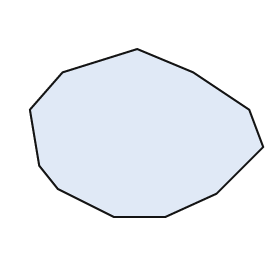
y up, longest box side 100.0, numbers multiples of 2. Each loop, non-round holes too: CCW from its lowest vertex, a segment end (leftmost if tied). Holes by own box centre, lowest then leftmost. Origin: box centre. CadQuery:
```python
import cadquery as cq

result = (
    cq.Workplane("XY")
    .moveTo(-14.0, -36.0)
    .lineTo(8.0, -36.0)
    .lineTo(30.0, -26.0)
    .lineTo(50.0, -6.0)
    .lineTo(44.0, 10.0)
    .lineTo(20.0, 26.0)
    .lineTo(-4.0, 36.0)
    .lineTo(-36.0, 26.0)
    .lineTo(-50.0, 10.0)
    .lineTo(-46.0, -14.0)
    .lineTo(-38.0, -24.0)
    .close()
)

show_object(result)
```